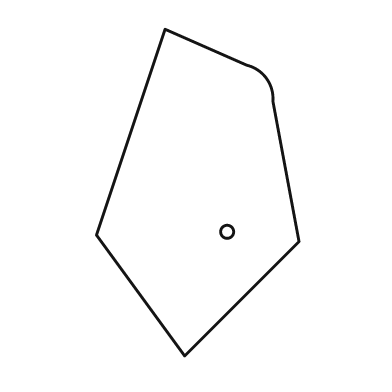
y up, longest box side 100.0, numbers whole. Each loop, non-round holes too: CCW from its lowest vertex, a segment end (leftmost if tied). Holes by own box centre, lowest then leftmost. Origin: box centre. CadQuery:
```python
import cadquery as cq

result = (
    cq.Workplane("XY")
    .moveTo(-4.0, -50.0)
    .lineTo(31.0, -15.0)
    .lineTo(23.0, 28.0)
    .threePointArc((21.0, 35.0), (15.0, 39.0))
    .lineTo(-10.0, 50.0)
    .lineTo(-31.0, -13.0)
    .close()
    .moveTo(9.0, -12.0)
    .circle(2.0)
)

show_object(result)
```